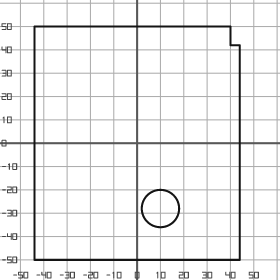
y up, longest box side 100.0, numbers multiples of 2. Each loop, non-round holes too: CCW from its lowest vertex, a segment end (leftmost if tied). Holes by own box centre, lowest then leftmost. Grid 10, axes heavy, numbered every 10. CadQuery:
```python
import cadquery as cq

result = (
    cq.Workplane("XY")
    .moveTo(-44.0, -50.0)
    .lineTo(44.0, -50.0)
    .lineTo(44.0, 42.0)
    .lineTo(40.0, 42.0)
    .lineTo(40.0, 50.0)
    .lineTo(-44.0, 50.0)
    .close()
    .moveTo(10.0, -28.0)
    .circle(8.0)
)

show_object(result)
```